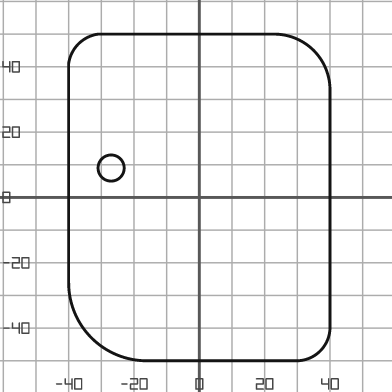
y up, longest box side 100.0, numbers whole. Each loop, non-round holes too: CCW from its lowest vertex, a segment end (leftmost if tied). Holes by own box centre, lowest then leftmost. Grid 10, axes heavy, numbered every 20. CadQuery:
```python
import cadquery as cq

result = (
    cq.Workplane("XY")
    .moveTo(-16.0, -50.0)
    .lineTo(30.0, -50.0)
    .threePointArc((37.0, -47.0), (40.0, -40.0))
    .lineTo(40.0, 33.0)
    .threePointArc((35.0, 45.0), (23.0, 50.0))
    .lineTo(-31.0, 50.0)
    .threePointArc((-37.0, 47.0), (-40.0, 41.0))
    .lineTo(-40.0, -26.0)
    .threePointArc((-33.0, -43.0), (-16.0, -50.0))
    .close()
    .moveTo(-27.0, 9.0)
    .circle(4.0)
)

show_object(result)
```